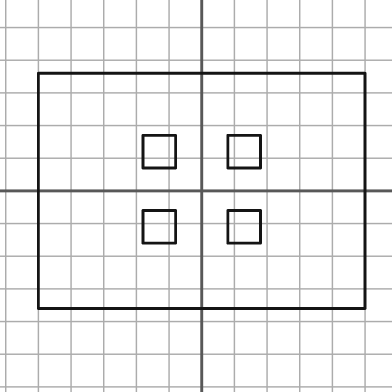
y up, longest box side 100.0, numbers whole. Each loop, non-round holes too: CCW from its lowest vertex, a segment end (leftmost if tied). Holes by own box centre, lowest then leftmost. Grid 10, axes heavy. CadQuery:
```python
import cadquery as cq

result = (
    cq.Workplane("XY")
    .moveTo(-50.0, -36.0)
    .lineTo(50.0, -36.0)
    .lineTo(50.0, 36.0)
    .lineTo(-50.0, 36.0)
    .close()
    .moveTo(-18.0, -16.0)
    .lineTo(-8.0, -16.0)
    .lineTo(-8.0, -6.0)
    .lineTo(-18.0, -6.0)
    .close()
    .moveTo(8.0, -16.0)
    .lineTo(18.0, -16.0)
    .lineTo(18.0, -6.0)
    .lineTo(8.0, -6.0)
    .close()
    .moveTo(-18.0, 7.0)
    .lineTo(-8.0, 7.0)
    .lineTo(-8.0, 17.0)
    .lineTo(-18.0, 17.0)
    .close()
    .moveTo(8.0, 7.0)
    .lineTo(18.0, 7.0)
    .lineTo(18.0, 17.0)
    .lineTo(8.0, 17.0)
    .close()
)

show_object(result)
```